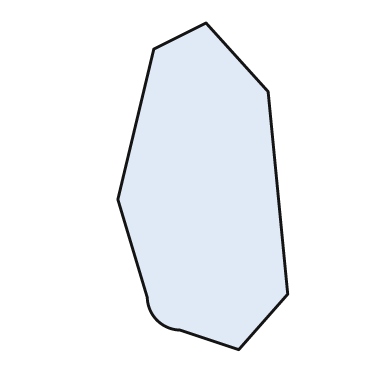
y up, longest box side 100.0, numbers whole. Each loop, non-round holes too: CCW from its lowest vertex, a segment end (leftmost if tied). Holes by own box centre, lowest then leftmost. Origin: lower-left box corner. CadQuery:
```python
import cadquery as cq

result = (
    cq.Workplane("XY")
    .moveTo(37.0, 0.0)
    .lineTo(52.0, 17.0)
    .lineTo(46.0, 79.0)
    .lineTo(27.0, 100.0)
    .lineTo(11.0, 92.0)
    .lineTo(0.0, 46.0)
    .lineTo(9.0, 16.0)
    .threePointArc((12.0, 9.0), (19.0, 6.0))
    .close()
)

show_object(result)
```